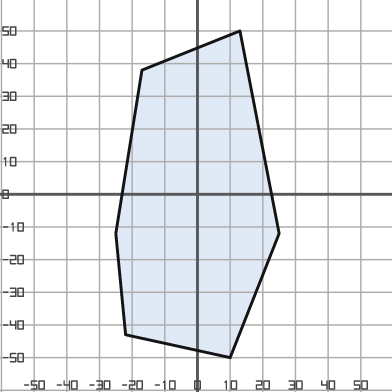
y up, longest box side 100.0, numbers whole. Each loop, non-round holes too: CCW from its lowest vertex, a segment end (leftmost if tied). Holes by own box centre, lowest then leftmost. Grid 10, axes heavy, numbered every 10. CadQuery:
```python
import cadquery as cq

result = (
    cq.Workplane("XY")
    .moveTo(10.0, -50.0)
    .lineTo(25.0, -12.0)
    .lineTo(13.0, 50.0)
    .lineTo(-17.0, 38.0)
    .lineTo(-25.0, -12.0)
    .lineTo(-22.0, -43.0)
    .close()
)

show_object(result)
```